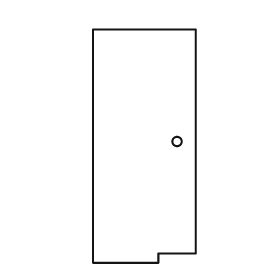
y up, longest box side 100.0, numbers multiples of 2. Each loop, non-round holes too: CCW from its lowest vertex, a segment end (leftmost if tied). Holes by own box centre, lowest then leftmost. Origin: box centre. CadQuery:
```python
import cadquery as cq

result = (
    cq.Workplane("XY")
    .moveTo(-22.0, -50.0)
    .lineTo(6.0, -50.0)
    .lineTo(6.0, -46.0)
    .lineTo(22.0, -46.0)
    .lineTo(22.0, 50.0)
    .lineTo(-22.0, 50.0)
    .close()
    .moveTo(14.0, 2.0)
    .circle(2.0)
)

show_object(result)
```